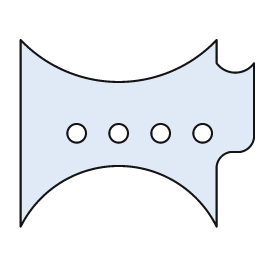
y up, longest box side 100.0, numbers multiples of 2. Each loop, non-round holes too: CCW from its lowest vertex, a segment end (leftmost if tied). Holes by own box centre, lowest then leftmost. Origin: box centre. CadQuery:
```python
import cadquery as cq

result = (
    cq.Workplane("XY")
    .moveTo(-50.0, -40.0)
    .threePointArc((-8.0, -14.0), (34.0, -40.0))
    .lineTo(34.0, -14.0)
    .threePointArc((36.0, -10.0), (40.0, -8.0))
    .lineTo(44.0, -8.0)
    .threePointArc((48.0, -6.0), (50.0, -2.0))
    .lineTo(50.0, 30.0)
    .threePointArc((42.0, 26.0), (34.0, 30.0))
    .lineTo(34.0, 40.0)
    .threePointArc((-8.0, 22.0), (-50.0, 40.0))
    .close()
    .moveTo(-26.0, 0.0)
    .circle(4.0)
    .moveTo(-8.0, 0.0)
    .circle(4.0)
    .moveTo(10.0, 0.0)
    .circle(4.0)
    .moveTo(28.0, 0.0)
    .circle(4.0)
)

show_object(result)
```